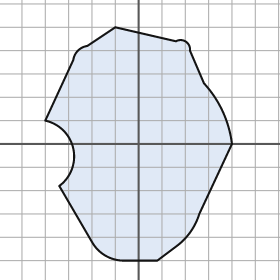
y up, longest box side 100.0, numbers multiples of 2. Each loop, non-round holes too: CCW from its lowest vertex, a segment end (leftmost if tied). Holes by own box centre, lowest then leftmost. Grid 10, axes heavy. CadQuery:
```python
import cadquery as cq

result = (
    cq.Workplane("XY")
    .moveTo(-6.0, -50.0)
    .lineTo(8.0, -50.0)
    .lineTo(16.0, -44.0)
    .threePointArc((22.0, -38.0), (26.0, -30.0))
    .lineTo(40.0, 0.0)
    .threePointArc((36.0, 14.0), (28.0, 26.0))
    .lineTo(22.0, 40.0)
    .threePointArc((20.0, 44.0), (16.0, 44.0))
    .lineTo(-10.0, 50.0)
    .lineTo(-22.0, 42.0)
    .threePointArc((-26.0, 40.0), (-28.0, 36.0))
    .lineTo(-40.0, 10.0)
    .threePointArc((-28.0, -2.0), (-34.0, -18.0))
    .lineTo(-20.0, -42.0)
    .threePointArc((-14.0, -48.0), (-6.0, -50.0))
    .close()
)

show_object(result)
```